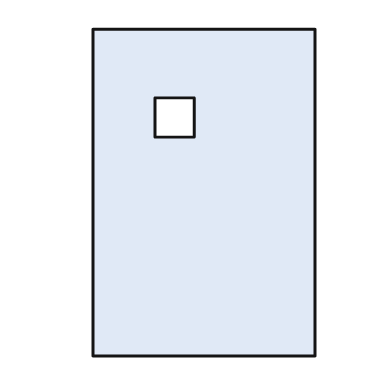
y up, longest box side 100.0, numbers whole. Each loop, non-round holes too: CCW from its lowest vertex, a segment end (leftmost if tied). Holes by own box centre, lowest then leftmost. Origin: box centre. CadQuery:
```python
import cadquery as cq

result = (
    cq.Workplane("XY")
    .moveTo(-34.0, -50.0)
    .lineTo(34.0, -50.0)
    .lineTo(34.0, 50.0)
    .lineTo(-34.0, 50.0)
    .close()
    .moveTo(-15.0, 17.0)
    .lineTo(-3.0, 17.0)
    .lineTo(-3.0, 29.0)
    .lineTo(-15.0, 29.0)
    .close()
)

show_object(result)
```